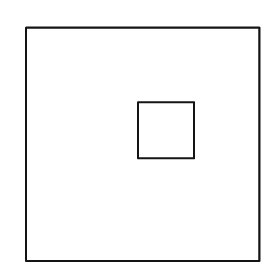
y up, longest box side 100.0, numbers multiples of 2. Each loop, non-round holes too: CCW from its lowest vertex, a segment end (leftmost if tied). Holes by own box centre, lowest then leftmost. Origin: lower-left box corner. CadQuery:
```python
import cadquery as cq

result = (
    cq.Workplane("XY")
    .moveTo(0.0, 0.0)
    .lineTo(100.0, 0.0)
    .lineTo(100.0, 100.0)
    .lineTo(0.0, 100.0)
    .close()
    .moveTo(48.0, 44.0)
    .lineTo(72.0, 44.0)
    .lineTo(72.0, 68.0)
    .lineTo(48.0, 68.0)
    .close()
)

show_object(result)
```